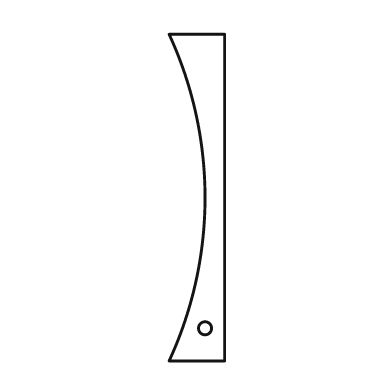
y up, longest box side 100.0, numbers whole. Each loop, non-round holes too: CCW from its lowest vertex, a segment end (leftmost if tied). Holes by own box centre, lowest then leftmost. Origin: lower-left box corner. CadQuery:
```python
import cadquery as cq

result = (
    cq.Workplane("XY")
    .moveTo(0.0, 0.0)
    .lineTo(17.0, 0.0)
    .lineTo(17.0, 100.0)
    .lineTo(0.0, 100.0)
    .threePointArc((11.0, 50.0), (0.0, 0.0))
    .close()
    .moveTo(11.0, 10.0)
    .circle(2.0)
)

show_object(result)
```